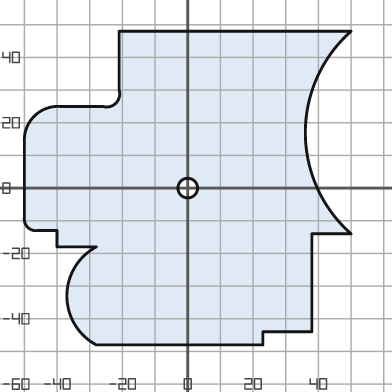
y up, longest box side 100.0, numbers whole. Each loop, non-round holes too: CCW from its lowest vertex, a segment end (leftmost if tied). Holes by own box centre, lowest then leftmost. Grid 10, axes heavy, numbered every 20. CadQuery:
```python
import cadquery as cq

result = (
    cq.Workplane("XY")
    .moveTo(-28.0, -48.0)
    .lineTo(23.0, -48.0)
    .lineTo(23.0, -44.0)
    .lineTo(38.0, -44.0)
    .lineTo(38.0, -14.0)
    .lineTo(50.0, -14.0)
    .threePointArc((36.0, 17.0), (50.0, 48.0))
    .lineTo(-21.0, 48.0)
    .lineTo(-21.0, 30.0)
    .threePointArc((-22.0, 26.0), (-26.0, 25.0))
    .lineTo(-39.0, 25.0)
    .threePointArc((-47.0, 22.0), (-50.0, 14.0))
    .lineTo(-50.0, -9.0)
    .threePointArc((-49.0, -12.0), (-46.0, -13.0))
    .lineTo(-40.0, -13.0)
    .lineTo(-40.0, -18.0)
    .lineTo(-28.0, -18.0)
    .threePointArc((-37.0, -33.0), (-28.0, -48.0))
    .close()
    .moveTo(0.0, 0.0)
    .circle(3.0)
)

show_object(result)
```